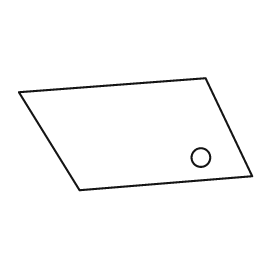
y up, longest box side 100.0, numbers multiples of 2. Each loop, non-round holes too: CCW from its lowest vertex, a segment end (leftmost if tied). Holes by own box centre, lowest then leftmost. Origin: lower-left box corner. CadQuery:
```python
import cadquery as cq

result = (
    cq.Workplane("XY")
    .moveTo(26.0, 0.0)
    .lineTo(100.0, 6.0)
    .lineTo(80.0, 48.0)
    .lineTo(0.0, 42.0)
    .close()
    .moveTo(78.0, 14.0)
    .circle(4.0)
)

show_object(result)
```